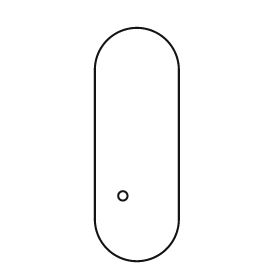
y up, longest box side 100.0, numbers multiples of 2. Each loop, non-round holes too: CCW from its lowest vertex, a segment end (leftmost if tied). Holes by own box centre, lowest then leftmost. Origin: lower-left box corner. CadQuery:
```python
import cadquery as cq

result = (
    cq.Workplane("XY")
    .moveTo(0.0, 18.0)
    .threePointArc((18.0, 0.0), (36.0, 18.0))
    .lineTo(36.0, 82.0)
    .threePointArc((18.0, 100.0), (0.0, 82.0))
    .close()
    .moveTo(12.0, 28.0)
    .circle(2.0)
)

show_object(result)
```